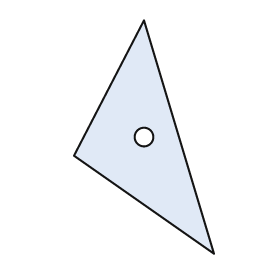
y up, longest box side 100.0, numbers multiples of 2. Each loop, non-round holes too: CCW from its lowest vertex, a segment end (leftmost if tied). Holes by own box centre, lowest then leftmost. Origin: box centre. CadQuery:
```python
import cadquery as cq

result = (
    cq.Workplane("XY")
    .moveTo(30.0, -50.0)
    .lineTo(0.0, 50.0)
    .lineTo(-30.0, -8.0)
    .close()
    .moveTo(0.0, 0.0)
    .circle(4.0)
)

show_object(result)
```